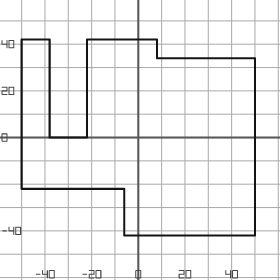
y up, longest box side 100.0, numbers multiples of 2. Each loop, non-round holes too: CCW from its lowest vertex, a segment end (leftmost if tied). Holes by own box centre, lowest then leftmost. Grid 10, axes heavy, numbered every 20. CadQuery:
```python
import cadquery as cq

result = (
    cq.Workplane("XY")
    .moveTo(-6.0, -42.0)
    .lineTo(50.0, -42.0)
    .lineTo(50.0, 34.0)
    .lineTo(8.0, 34.0)
    .lineTo(8.0, 42.0)
    .lineTo(-22.0, 42.0)
    .lineTo(-22.0, 0.0)
    .lineTo(-38.0, 0.0)
    .lineTo(-38.0, 42.0)
    .lineTo(-50.0, 42.0)
    .lineTo(-50.0, -22.0)
    .lineTo(-6.0, -22.0)
    .close()
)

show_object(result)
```